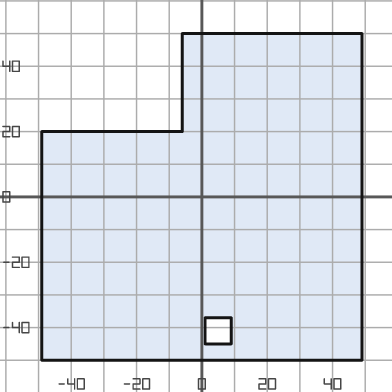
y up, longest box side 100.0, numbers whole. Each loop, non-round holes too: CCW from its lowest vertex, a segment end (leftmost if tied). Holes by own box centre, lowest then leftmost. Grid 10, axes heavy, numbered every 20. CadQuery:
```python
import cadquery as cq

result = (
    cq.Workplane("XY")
    .moveTo(-49.0, -50.0)
    .lineTo(49.0, -50.0)
    .lineTo(49.0, 50.0)
    .lineTo(-6.0, 50.0)
    .lineTo(-6.0, 20.0)
    .lineTo(-49.0, 20.0)
    .close()
    .moveTo(1.0, -45.0)
    .lineTo(9.0, -45.0)
    .lineTo(9.0, -37.0)
    .lineTo(1.0, -37.0)
    .close()
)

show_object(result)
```